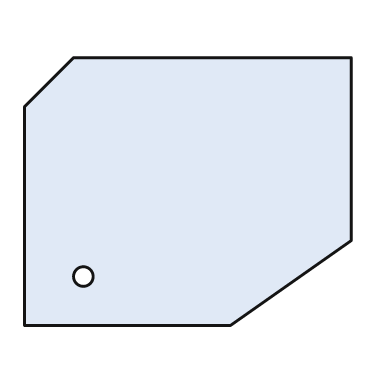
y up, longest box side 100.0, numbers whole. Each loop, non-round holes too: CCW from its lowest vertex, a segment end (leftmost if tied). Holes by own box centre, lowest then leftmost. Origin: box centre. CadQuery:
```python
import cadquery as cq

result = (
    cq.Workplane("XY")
    .moveTo(-50.0, -41.0)
    .lineTo(13.0, -41.0)
    .lineTo(50.0, -15.0)
    .lineTo(50.0, 41.0)
    .lineTo(-35.0, 41.0)
    .lineTo(-50.0, 26.0)
    .close()
    .moveTo(-32.0, -26.0)
    .circle(3.0)
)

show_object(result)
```